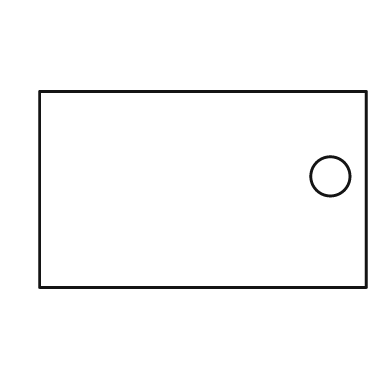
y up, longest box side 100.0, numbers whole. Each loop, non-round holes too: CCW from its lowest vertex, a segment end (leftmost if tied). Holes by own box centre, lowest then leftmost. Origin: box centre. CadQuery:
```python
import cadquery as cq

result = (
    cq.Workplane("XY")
    .moveTo(-50.0, -30.0)
    .lineTo(50.0, -30.0)
    .lineTo(50.0, 30.0)
    .lineTo(-50.0, 30.0)
    .close()
    .moveTo(39.0, 4.0)
    .circle(6.0)
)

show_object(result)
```